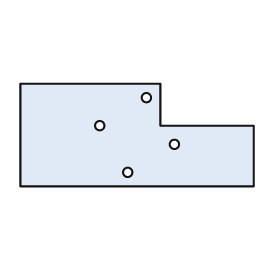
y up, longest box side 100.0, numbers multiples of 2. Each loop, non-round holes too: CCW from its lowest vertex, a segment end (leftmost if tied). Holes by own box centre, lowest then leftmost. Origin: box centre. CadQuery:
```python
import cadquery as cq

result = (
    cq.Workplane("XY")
    .moveTo(-50.0, -22.0)
    .lineTo(50.0, -22.0)
    .lineTo(50.0, 4.0)
    .lineTo(10.0, 4.0)
    .lineTo(10.0, 22.0)
    .lineTo(-50.0, 22.0)
    .close()
    .moveTo(-4.0, -16.0)
    .circle(2.0)
    .moveTo(16.0, -4.0)
    .circle(2.0)
    .moveTo(-16.0, 4.0)
    .circle(2.0)
    .moveTo(4.0, 16.0)
    .circle(2.0)
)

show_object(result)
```